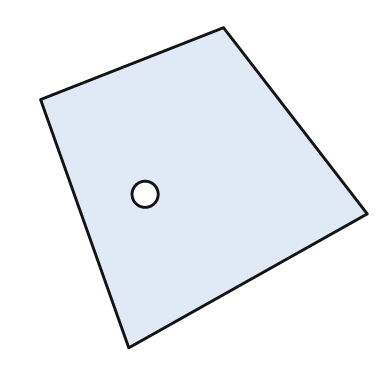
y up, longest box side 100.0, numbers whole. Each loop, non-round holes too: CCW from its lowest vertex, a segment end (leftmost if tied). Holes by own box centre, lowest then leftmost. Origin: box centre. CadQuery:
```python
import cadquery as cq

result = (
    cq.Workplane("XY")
    .moveTo(-23.0, -49.0)
    .lineTo(50.0, -8.0)
    .lineTo(6.0, 49.0)
    .lineTo(-50.0, 27.0)
    .close()
    .moveTo(-18.0, -2.0)
    .circle(4.0)
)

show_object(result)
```